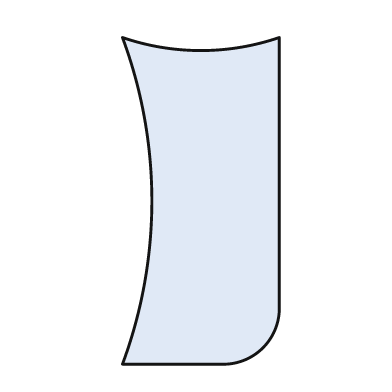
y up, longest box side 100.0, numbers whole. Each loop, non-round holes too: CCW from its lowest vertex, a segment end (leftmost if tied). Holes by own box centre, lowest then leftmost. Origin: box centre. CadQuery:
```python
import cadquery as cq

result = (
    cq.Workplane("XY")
    .moveTo(-24.0, -50.0)
    .lineTo(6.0, -50.0)
    .threePointArc((19.0, -45.0), (24.0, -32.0))
    .lineTo(24.0, 50.0)
    .threePointArc((0.0, 46.0), (-24.0, 50.0))
    .threePointArc((-15.0, 0.0), (-24.0, -50.0))
    .close()
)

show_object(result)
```